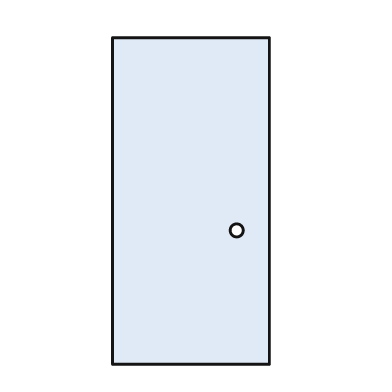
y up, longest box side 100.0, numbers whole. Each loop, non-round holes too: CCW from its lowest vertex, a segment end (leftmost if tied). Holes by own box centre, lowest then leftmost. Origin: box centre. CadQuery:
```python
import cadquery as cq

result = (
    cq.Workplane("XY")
    .moveTo(-24.0, -50.0)
    .lineTo(24.0, -50.0)
    .lineTo(24.0, 50.0)
    .lineTo(-24.0, 50.0)
    .close()
    .moveTo(14.0, -9.0)
    .circle(2.0)
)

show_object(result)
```